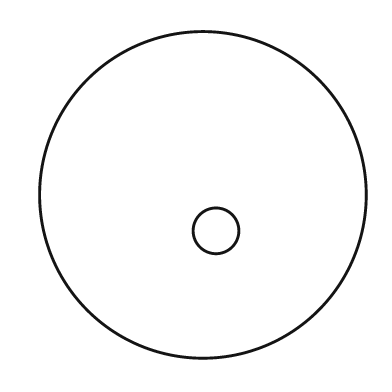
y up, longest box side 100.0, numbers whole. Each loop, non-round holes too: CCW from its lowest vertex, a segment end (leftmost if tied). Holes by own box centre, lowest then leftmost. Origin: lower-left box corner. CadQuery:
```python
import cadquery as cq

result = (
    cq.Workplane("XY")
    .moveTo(50.0, 50.0)
    .circle(50.0)
    .moveTo(54.0, 39.0)
    .circle(7.0)
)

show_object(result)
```